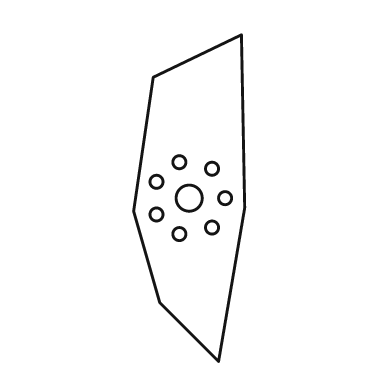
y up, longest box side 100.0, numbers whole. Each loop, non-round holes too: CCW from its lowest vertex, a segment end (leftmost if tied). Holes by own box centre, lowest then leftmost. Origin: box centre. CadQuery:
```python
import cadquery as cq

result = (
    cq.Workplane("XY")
    .moveTo(9.0, -50.0)
    .lineTo(17.0, -3.0)
    .lineTo(16.0, 50.0)
    .lineTo(-11.0, 37.0)
    .lineTo(-17.0, -4.0)
    .lineTo(-9.0, -32.0)
    .close()
    .moveTo(-3.0, -11.0)
    .circle(2.0)
    .moveTo(7.0, -9.0)
    .circle(2.0)
    .moveTo(-10.0, -5.0)
    .circle(2.0)
    .moveTo(0.0, 0.0)
    .circle(4.0)
    .moveTo(11.0, 0.0)
    .circle(2.0)
    .moveTo(-10.0, 5.0)
    .circle(2.0)
    .moveTo(7.0, 9.0)
    .circle(2.0)
    .moveTo(-3.0, 11.0)
    .circle(2.0)
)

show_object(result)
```